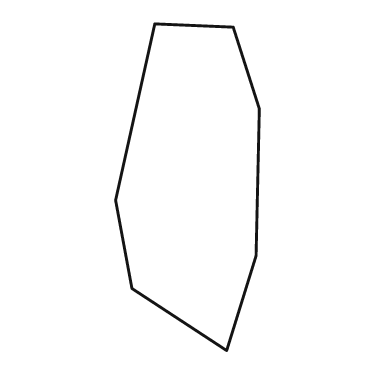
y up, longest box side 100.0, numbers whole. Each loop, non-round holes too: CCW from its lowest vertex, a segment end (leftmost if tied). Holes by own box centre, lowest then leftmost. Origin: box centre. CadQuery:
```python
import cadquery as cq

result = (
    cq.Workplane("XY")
    .moveTo(12.0, -50.0)
    .lineTo(21.0, -21.0)
    .lineTo(22.0, 24.0)
    .lineTo(14.0, 49.0)
    .lineTo(-10.0, 50.0)
    .lineTo(-22.0, -4.0)
    .lineTo(-17.0, -31.0)
    .close()
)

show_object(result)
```